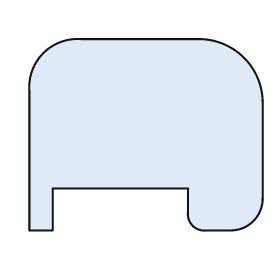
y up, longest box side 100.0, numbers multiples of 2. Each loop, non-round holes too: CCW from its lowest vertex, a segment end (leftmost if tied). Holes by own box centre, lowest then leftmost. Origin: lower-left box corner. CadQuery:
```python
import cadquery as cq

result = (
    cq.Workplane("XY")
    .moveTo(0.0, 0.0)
    .lineTo(10.0, 0.0)
    .lineTo(10.0, 18.0)
    .lineTo(68.0, 18.0)
    .lineTo(68.0, 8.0)
    .threePointArc((70.0, 2.0), (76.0, 0.0))
    .lineTo(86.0, 0.0)
    .threePointArc((96.0, 4.0), (100.0, 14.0))
    .lineTo(100.0, 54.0)
    .threePointArc((92.0, 74.0), (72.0, 82.0))
    .lineTo(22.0, 82.0)
    .threePointArc((6.0, 76.0), (0.0, 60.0))
    .close()
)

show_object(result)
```